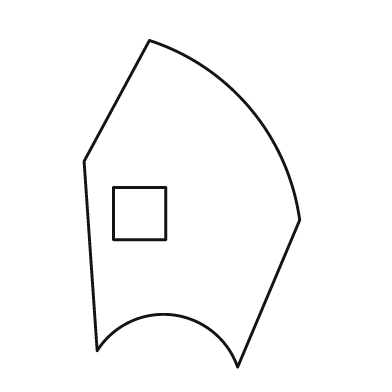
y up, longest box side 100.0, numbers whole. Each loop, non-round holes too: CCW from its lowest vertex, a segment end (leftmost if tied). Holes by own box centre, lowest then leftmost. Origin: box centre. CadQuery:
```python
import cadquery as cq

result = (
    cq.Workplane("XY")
    .moveTo(14.0, -50.0)
    .lineTo(33.0, -5.0)
    .threePointArc((18.0, 29.0), (-13.0, 50.0))
    .lineTo(-33.0, 13.0)
    .lineTo(-29.0, -45.0)
    .threePointArc((-6.0, -34.0), (14.0, -50.0))
    .close()
    .moveTo(-24.0, -11.0)
    .lineTo(-8.0, -11.0)
    .lineTo(-8.0, 5.0)
    .lineTo(-24.0, 5.0)
    .close()
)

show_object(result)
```